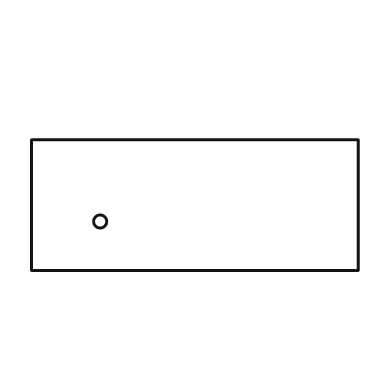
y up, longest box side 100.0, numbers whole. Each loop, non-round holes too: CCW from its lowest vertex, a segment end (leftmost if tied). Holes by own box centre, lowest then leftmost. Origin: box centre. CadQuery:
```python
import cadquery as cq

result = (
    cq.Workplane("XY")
    .moveTo(-50.0, -20.0)
    .lineTo(50.0, -20.0)
    .lineTo(50.0, 20.0)
    .lineTo(-50.0, 20.0)
    .close()
    .moveTo(-29.0, -5.0)
    .circle(2.0)
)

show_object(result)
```